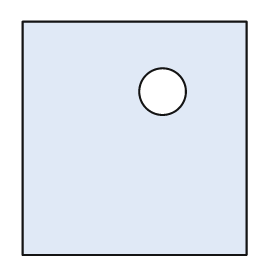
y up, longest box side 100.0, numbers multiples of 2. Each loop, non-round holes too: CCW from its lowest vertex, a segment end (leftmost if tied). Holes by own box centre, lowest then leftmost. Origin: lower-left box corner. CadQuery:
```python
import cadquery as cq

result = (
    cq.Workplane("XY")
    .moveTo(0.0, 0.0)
    .lineTo(96.0, 0.0)
    .lineTo(96.0, 100.0)
    .lineTo(0.0, 100.0)
    .close()
    .moveTo(60.0, 70.0)
    .circle(10.0)
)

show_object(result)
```